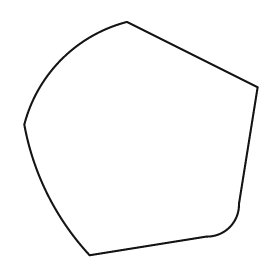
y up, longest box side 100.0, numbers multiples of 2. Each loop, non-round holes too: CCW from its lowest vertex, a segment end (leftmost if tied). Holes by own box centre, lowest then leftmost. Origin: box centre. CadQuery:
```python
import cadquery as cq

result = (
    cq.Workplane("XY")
    .moveTo(-22.0, -50.0)
    .lineTo(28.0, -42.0)
    .threePointArc((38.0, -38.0), (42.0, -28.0))
    .lineTo(50.0, 22.0)
    .lineTo(-6.0, 50.0)
    .threePointArc((-34.0, 34.0), (-50.0, 6.0))
    .threePointArc((-40.0, -24.0), (-22.0, -50.0))
    .close()
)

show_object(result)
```